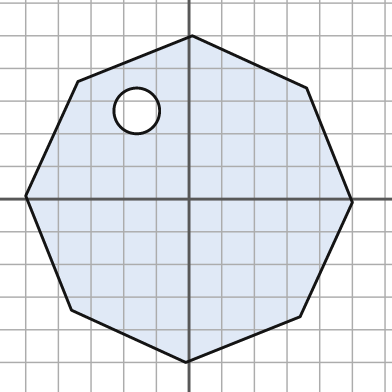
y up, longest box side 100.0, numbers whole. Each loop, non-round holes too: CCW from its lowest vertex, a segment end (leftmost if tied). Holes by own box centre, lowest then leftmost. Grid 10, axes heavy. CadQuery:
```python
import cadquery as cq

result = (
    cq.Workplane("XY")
    .moveTo(-1.0, -50.0)
    .lineTo(34.0, -36.0)
    .lineTo(50.0, -1.0)
    .lineTo(36.0, 34.0)
    .lineTo(1.0, 50.0)
    .lineTo(-34.0, 36.0)
    .lineTo(-50.0, 1.0)
    .lineTo(-36.0, -34.0)
    .close()
    .moveTo(-16.0, 27.0)
    .circle(7.0)
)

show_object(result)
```